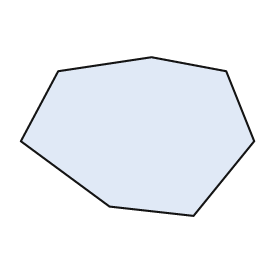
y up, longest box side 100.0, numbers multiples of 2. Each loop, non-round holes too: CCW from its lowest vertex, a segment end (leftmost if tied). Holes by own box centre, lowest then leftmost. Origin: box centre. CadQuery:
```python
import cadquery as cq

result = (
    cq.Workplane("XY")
    .moveTo(24.0, -34.0)
    .lineTo(50.0, -2.0)
    .lineTo(38.0, 28.0)
    .lineTo(6.0, 34.0)
    .lineTo(-34.0, 28.0)
    .lineTo(-50.0, -2.0)
    .lineTo(-12.0, -30.0)
    .close()
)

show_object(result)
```